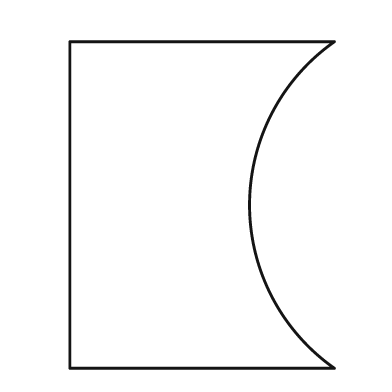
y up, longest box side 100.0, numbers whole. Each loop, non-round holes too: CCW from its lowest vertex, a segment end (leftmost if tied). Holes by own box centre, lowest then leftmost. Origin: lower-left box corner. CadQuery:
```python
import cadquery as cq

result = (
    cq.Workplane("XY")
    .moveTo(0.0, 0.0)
    .lineTo(81.0, 0.0)
    .threePointArc((55.0, 50.0), (81.0, 100.0))
    .lineTo(0.0, 100.0)
    .close()
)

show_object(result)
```